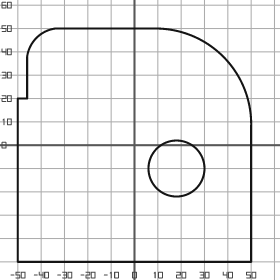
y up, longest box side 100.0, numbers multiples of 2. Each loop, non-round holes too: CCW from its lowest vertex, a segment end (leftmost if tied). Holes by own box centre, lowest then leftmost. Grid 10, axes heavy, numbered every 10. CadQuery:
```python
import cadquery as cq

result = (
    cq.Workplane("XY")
    .moveTo(-50.0, -50.0)
    .lineTo(50.0, -50.0)
    .lineTo(50.0, 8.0)
    .threePointArc((38.0, 38.0), (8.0, 50.0))
    .lineTo(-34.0, 50.0)
    .threePointArc((-42.0, 46.0), (-46.0, 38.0))
    .lineTo(-46.0, 20.0)
    .lineTo(-50.0, 20.0)
    .close()
    .moveTo(18.0, -10.0)
    .circle(12.0)
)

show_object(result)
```